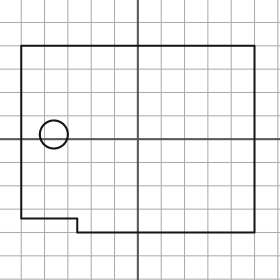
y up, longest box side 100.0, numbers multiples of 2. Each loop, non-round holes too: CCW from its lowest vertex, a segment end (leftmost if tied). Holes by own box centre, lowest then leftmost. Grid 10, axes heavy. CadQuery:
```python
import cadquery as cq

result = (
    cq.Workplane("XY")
    .moveTo(-26.0, -40.0)
    .lineTo(50.0, -40.0)
    .lineTo(50.0, 40.0)
    .lineTo(-50.0, 40.0)
    .lineTo(-50.0, -34.0)
    .lineTo(-26.0, -34.0)
    .close()
    .moveTo(-36.0, 2.0)
    .circle(6.0)
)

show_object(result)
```